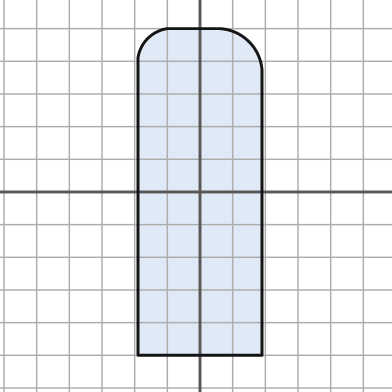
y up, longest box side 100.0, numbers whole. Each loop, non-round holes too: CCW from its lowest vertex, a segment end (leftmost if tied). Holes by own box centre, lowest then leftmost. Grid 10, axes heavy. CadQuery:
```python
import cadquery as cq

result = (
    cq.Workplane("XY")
    .moveTo(-19.0, -50.0)
    .lineTo(19.0, -50.0)
    .lineTo(19.0, 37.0)
    .threePointArc((15.0, 46.0), (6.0, 50.0))
    .lineTo(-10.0, 50.0)
    .threePointArc((-16.0, 47.0), (-19.0, 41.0))
    .close()
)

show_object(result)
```